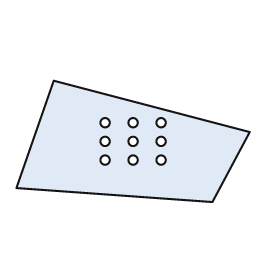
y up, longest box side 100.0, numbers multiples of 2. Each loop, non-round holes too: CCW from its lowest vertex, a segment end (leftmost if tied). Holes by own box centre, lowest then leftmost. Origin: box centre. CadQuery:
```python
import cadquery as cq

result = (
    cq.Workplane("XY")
    .moveTo(34.0, -26.0)
    .lineTo(50.0, 4.0)
    .lineTo(-34.0, 26.0)
    .lineTo(-50.0, -20.0)
    .close()
    .moveTo(-12.0, -8.0)
    .circle(2.0)
    .moveTo(0.0, -8.0)
    .circle(2.0)
    .moveTo(12.0, -8.0)
    .circle(2.0)
    .moveTo(-12.0, 0.0)
    .circle(2.0)
    .moveTo(0.0, 0.0)
    .circle(2.0)
    .moveTo(12.0, 0.0)
    .circle(2.0)
    .moveTo(-12.0, 8.0)
    .circle(2.0)
    .moveTo(0.0, 8.0)
    .circle(2.0)
    .moveTo(12.0, 8.0)
    .circle(2.0)
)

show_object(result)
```